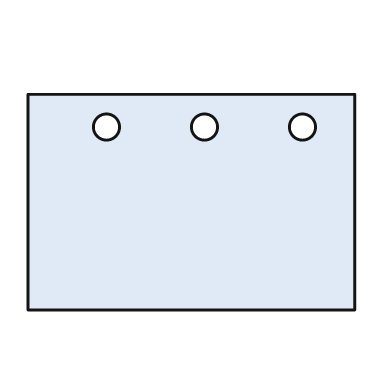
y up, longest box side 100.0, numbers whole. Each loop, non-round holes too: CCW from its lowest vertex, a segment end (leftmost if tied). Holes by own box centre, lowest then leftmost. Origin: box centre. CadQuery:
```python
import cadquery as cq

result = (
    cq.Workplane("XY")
    .moveTo(-50.0, -33.0)
    .lineTo(50.0, -33.0)
    .lineTo(50.0, 33.0)
    .lineTo(-50.0, 33.0)
    .close()
    .moveTo(-26.0, 23.0)
    .circle(4.0)
    .moveTo(4.0, 23.0)
    .circle(4.0)
    .moveTo(34.0, 23.0)
    .circle(4.0)
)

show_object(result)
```